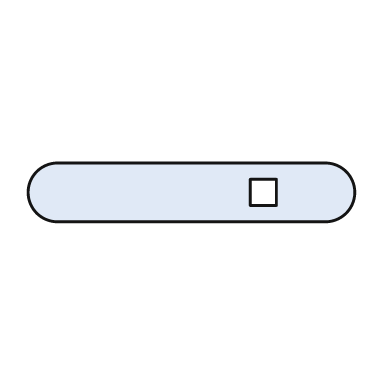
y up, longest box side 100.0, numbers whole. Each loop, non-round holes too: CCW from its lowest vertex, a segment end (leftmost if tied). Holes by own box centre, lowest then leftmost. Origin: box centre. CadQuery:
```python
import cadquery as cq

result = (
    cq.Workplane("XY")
    .moveTo(-41.0, -9.0)
    .lineTo(41.0, -9.0)
    .threePointArc((50.0, 0.0), (41.0, 9.0))
    .lineTo(-41.0, 9.0)
    .threePointArc((-50.0, 0.0), (-41.0, -9.0))
    .close()
    .moveTo(18.0, -4.0)
    .lineTo(26.0, -4.0)
    .lineTo(26.0, 4.0)
    .lineTo(18.0, 4.0)
    .close()
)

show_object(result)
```